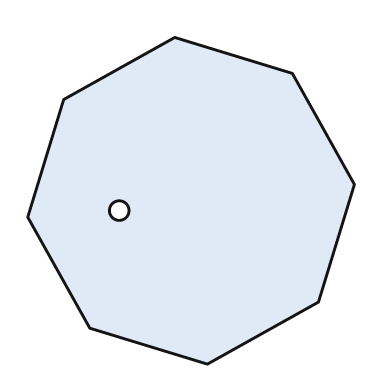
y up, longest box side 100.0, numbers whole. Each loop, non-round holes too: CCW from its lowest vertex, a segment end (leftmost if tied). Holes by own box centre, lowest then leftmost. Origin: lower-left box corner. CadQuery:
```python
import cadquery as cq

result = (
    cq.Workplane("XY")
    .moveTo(55.0, 0.0)
    .lineTo(89.0, 19.0)
    .lineTo(100.0, 55.0)
    .lineTo(81.0, 89.0)
    .lineTo(45.0, 100.0)
    .lineTo(11.0, 81.0)
    .lineTo(0.0, 45.0)
    .lineTo(19.0, 11.0)
    .close()
    .moveTo(28.0, 47.0)
    .circle(3.0)
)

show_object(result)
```